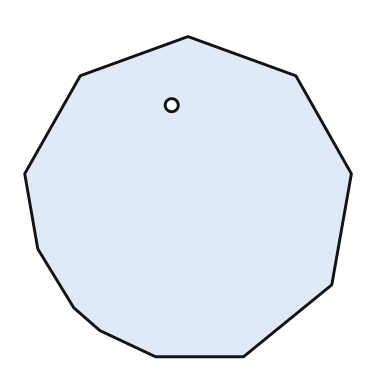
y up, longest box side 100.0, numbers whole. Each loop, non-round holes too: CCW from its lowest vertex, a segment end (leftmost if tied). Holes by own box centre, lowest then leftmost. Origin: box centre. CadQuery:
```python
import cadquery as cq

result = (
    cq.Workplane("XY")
    .moveTo(-10.0, -49.0)
    .lineTo(17.0, -49.0)
    .lineTo(44.0, -27.0)
    .lineTo(50.0, 7.0)
    .lineTo(33.0, 37.0)
    .lineTo(0.0, 49.0)
    .lineTo(-33.0, 37.0)
    .lineTo(-50.0, 7.0)
    .lineTo(-46.0, -16.0)
    .lineTo(-35.0, -34.0)
    .lineTo(-27.0, -41.0)
    .close()
    .moveTo(-5.0, 28.0)
    .circle(2.0)
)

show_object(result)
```